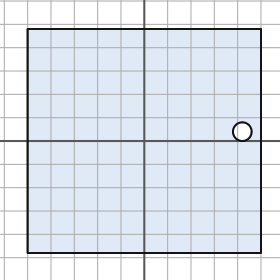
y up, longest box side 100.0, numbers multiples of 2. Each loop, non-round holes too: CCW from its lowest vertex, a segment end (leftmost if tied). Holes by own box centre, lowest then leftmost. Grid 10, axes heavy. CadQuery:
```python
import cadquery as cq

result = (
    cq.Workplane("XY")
    .moveTo(-50.0, -48.0)
    .lineTo(50.0, -48.0)
    .lineTo(50.0, 48.0)
    .lineTo(-50.0, 48.0)
    .close()
    .moveTo(42.0, 4.0)
    .circle(4.0)
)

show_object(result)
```